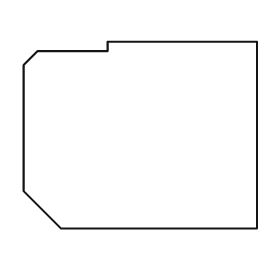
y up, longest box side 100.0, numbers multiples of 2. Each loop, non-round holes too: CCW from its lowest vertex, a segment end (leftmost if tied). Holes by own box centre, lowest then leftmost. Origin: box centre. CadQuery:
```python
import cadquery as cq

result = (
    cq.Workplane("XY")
    .moveTo(-34.0, -40.0)
    .lineTo(50.0, -40.0)
    .lineTo(50.0, 40.0)
    .lineTo(-14.0, 40.0)
    .lineTo(-14.0, 36.0)
    .lineTo(-44.0, 36.0)
    .lineTo(-50.0, 30.0)
    .lineTo(-50.0, -24.0)
    .close()
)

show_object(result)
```